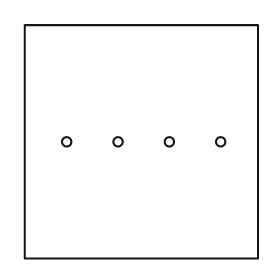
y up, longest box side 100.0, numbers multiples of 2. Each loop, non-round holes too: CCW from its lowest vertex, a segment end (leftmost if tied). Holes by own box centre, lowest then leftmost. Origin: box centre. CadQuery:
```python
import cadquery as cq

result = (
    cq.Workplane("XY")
    .moveTo(-50.0, -50.0)
    .lineTo(50.0, -50.0)
    .lineTo(50.0, 50.0)
    .lineTo(-50.0, 50.0)
    .close()
    .moveTo(-32.0, 0.0)
    .circle(2.0)
    .moveTo(-10.0, 0.0)
    .circle(2.0)
    .moveTo(12.0, 0.0)
    .circle(2.0)
    .moveTo(34.0, 0.0)
    .circle(2.0)
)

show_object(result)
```